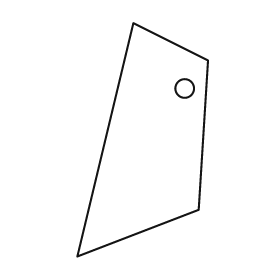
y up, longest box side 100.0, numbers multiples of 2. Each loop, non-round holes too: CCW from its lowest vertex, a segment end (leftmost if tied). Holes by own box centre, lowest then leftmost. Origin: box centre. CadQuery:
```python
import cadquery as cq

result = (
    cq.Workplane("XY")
    .moveTo(-28.0, -50.0)
    .lineTo(24.0, -30.0)
    .lineTo(28.0, 34.0)
    .lineTo(-4.0, 50.0)
    .close()
    .moveTo(18.0, 22.0)
    .circle(4.0)
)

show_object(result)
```